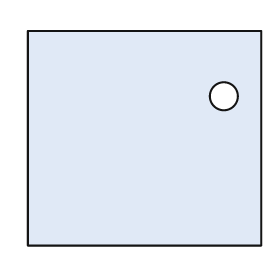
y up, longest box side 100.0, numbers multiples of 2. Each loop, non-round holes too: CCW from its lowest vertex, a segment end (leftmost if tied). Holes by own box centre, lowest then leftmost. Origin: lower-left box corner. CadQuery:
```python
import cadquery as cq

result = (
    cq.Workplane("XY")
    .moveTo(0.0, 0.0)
    .lineTo(100.0, 0.0)
    .lineTo(100.0, 92.0)
    .lineTo(0.0, 92.0)
    .close()
    .moveTo(84.0, 64.0)
    .circle(6.0)
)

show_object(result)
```